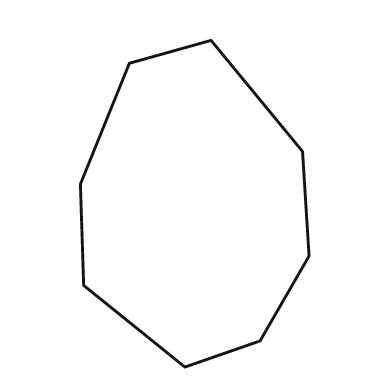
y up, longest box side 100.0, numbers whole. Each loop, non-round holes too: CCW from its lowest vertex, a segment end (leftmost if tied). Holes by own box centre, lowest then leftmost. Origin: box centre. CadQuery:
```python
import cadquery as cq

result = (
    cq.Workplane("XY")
    .moveTo(-3.0, -50.0)
    .lineTo(20.0, -42.0)
    .lineTo(35.0, -16.0)
    .lineTo(33.0, 16.0)
    .lineTo(5.0, 50.0)
    .lineTo(-20.0, 43.0)
    .lineTo(-35.0, 6.0)
    .lineTo(-34.0, -25.0)
    .close()
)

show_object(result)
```